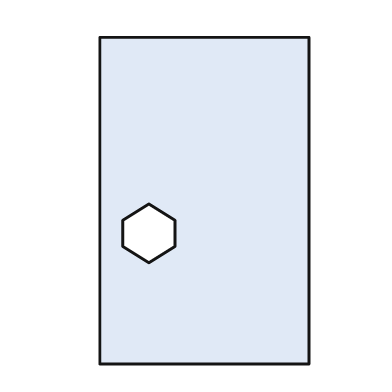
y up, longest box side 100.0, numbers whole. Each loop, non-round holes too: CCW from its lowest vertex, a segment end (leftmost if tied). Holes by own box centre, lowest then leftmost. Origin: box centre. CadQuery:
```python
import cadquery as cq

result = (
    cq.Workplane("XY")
    .moveTo(-32.0, -50.0)
    .lineTo(32.0, -50.0)
    .lineTo(32.0, 50.0)
    .lineTo(-32.0, 50.0)
    .close()
    .moveTo(-17.0, -19.0)
    .lineTo(-9.0, -14.0)
    .lineTo(-9.0, -6.0)
    .lineTo(-17.0, -1.0)
    .lineTo(-25.0, -6.0)
    .lineTo(-25.0, -14.0)
    .close()
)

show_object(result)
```